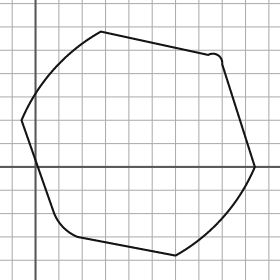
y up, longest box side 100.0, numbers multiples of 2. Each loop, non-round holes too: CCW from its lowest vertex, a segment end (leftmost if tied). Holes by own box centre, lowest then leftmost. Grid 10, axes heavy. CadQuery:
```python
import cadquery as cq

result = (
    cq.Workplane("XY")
    .moveTo(60.0, -38.0)
    .threePointArc((80.0, -22.0), (94.0, 0.0))
    .lineTo(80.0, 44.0)
    .threePointArc((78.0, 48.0), (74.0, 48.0))
    .lineTo(28.0, 58.0)
    .threePointArc((8.0, 42.0), (-6.0, 20.0))
    .lineTo(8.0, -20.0)
    .threePointArc((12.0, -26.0), (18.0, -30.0))
    .close()
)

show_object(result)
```